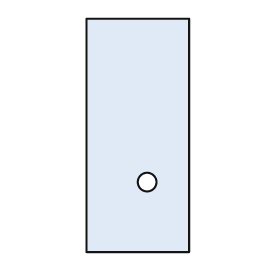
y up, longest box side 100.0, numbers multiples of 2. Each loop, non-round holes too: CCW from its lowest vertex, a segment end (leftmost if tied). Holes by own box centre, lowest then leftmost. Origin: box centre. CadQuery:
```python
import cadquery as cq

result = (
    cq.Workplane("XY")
    .moveTo(-22.0, -50.0)
    .lineTo(22.0, -50.0)
    .lineTo(22.0, 50.0)
    .lineTo(-22.0, 50.0)
    .close()
    .moveTo(4.0, -20.0)
    .circle(4.0)
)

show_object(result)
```